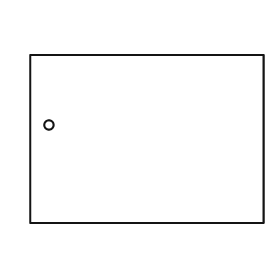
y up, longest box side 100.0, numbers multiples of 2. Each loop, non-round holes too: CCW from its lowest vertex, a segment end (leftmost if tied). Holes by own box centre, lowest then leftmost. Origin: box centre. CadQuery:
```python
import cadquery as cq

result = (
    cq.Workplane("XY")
    .moveTo(-50.0, -36.0)
    .lineTo(50.0, -36.0)
    .lineTo(50.0, 36.0)
    .lineTo(-50.0, 36.0)
    .close()
    .moveTo(-42.0, 6.0)
    .circle(2.0)
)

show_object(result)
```